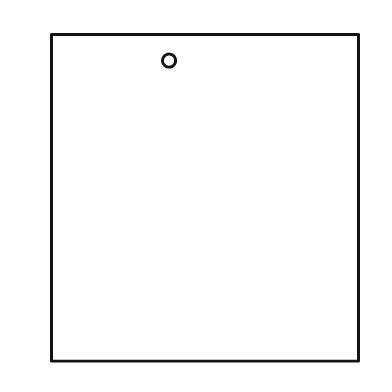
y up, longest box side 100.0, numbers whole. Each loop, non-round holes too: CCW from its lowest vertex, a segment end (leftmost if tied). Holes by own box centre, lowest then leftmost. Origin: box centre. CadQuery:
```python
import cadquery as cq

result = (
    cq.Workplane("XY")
    .moveTo(-47.0, -50.0)
    .lineTo(47.0, -50.0)
    .lineTo(47.0, 50.0)
    .lineTo(-47.0, 50.0)
    .close()
    .moveTo(-11.0, 42.0)
    .circle(2.0)
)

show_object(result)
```